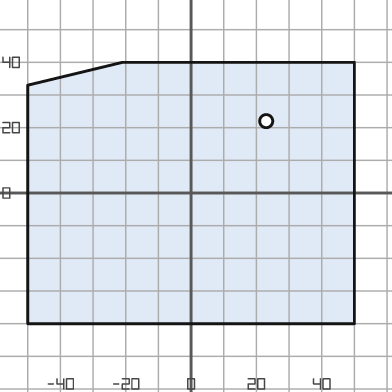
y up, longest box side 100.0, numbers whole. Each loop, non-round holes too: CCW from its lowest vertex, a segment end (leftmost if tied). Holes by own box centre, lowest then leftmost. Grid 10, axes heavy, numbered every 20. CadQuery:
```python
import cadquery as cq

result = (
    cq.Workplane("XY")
    .moveTo(-50.0, -40.0)
    .lineTo(50.0, -40.0)
    .lineTo(50.0, 40.0)
    .lineTo(-21.0, 40.0)
    .lineTo(-50.0, 33.0)
    .close()
    .moveTo(23.0, 22.0)
    .circle(2.0)
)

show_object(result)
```